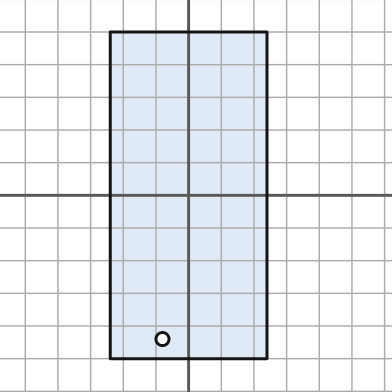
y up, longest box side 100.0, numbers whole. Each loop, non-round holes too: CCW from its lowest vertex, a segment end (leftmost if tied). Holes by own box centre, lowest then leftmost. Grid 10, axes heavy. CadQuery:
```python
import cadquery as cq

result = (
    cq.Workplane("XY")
    .moveTo(-24.0, -50.0)
    .lineTo(24.0, -50.0)
    .lineTo(24.0, 50.0)
    .lineTo(-24.0, 50.0)
    .close()
    .moveTo(-8.0, -44.0)
    .circle(2.0)
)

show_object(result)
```